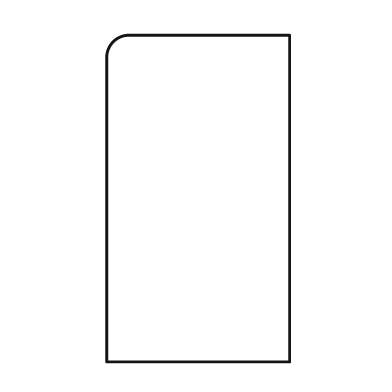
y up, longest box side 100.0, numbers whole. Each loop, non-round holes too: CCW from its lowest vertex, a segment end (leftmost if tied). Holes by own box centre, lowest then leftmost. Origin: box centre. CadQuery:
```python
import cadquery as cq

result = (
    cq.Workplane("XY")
    .moveTo(-28.0, -50.0)
    .lineTo(28.0, -50.0)
    .lineTo(28.0, 50.0)
    .lineTo(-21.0, 50.0)
    .threePointArc((-26.0, 48.0), (-28.0, 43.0))
    .close()
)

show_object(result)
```